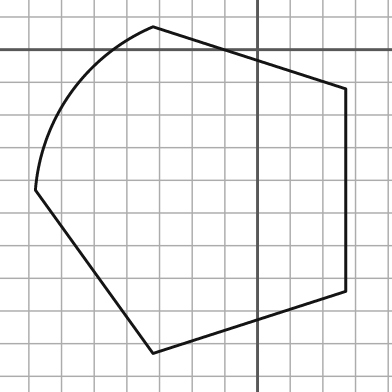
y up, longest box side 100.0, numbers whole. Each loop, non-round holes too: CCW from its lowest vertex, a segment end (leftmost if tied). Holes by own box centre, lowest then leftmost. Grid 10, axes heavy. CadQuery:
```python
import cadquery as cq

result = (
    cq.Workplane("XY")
    .moveTo(-32.0, -93.0)
    .lineTo(27.0, -74.0)
    .lineTo(27.0, -12.0)
    .lineTo(-32.0, 7.0)
    .threePointArc((-57.0, -13.0), (-68.0, -43.0))
    .close()
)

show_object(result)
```